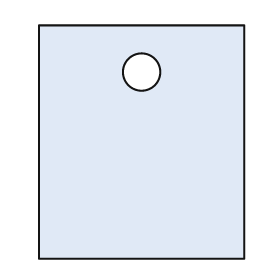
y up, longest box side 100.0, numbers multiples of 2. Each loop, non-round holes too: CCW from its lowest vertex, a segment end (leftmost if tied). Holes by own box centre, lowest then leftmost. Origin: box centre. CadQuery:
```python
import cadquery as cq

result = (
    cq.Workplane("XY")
    .moveTo(-44.0, -50.0)
    .lineTo(44.0, -50.0)
    .lineTo(44.0, 50.0)
    .lineTo(-44.0, 50.0)
    .close()
    .moveTo(0.0, 30.0)
    .circle(8.0)
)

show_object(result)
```